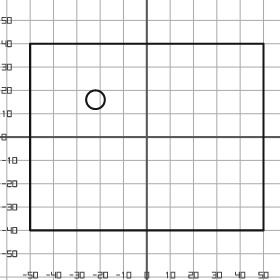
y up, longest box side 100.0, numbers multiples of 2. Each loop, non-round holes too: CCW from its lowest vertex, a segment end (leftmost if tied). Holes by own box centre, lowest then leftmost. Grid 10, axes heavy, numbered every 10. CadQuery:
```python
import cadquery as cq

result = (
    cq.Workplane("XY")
    .moveTo(-50.0, -40.0)
    .lineTo(50.0, -40.0)
    .lineTo(50.0, 40.0)
    .lineTo(-50.0, 40.0)
    .close()
    .moveTo(-22.0, 16.0)
    .circle(4.0)
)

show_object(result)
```